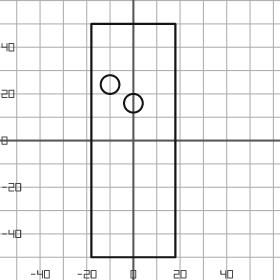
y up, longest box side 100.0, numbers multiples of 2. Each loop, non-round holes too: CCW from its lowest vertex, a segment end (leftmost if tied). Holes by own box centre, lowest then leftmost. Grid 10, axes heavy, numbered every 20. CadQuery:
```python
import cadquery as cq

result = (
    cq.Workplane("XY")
    .moveTo(-18.0, -50.0)
    .lineTo(18.0, -50.0)
    .lineTo(18.0, 50.0)
    .lineTo(-18.0, 50.0)
    .close()
    .moveTo(0.0, 16.0)
    .circle(4.0)
    .moveTo(-10.0, 24.0)
    .circle(4.0)
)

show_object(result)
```